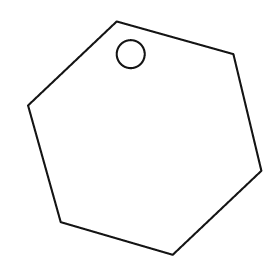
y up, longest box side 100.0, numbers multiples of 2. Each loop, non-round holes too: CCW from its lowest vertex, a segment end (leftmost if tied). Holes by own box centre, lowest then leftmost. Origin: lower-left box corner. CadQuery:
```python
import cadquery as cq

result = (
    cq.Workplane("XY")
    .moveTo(62.0, 0.0)
    .lineTo(100.0, 36.0)
    .lineTo(88.0, 86.0)
    .lineTo(38.0, 100.0)
    .lineTo(0.0, 64.0)
    .lineTo(14.0, 14.0)
    .close()
    .moveTo(44.0, 86.0)
    .circle(6.0)
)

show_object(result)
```